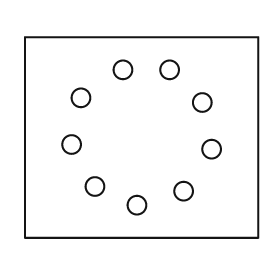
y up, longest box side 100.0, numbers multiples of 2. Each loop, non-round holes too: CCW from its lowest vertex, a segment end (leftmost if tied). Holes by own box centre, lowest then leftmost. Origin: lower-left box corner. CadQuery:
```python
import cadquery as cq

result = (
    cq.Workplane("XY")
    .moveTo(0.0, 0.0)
    .lineTo(100.0, 0.0)
    .lineTo(100.0, 86.0)
    .lineTo(0.0, 86.0)
    .close()
    .moveTo(48.0, 14.0)
    .circle(4.0)
    .moveTo(68.0, 20.0)
    .circle(4.0)
    .moveTo(30.0, 22.0)
    .circle(4.0)
    .moveTo(80.0, 38.0)
    .circle(4.0)
    .moveTo(20.0, 40.0)
    .circle(4.0)
    .moveTo(76.0, 58.0)
    .circle(4.0)
    .moveTo(24.0, 60.0)
    .circle(4.0)
    .moveTo(42.0, 72.0)
    .circle(4.0)
    .moveTo(62.0, 72.0)
    .circle(4.0)
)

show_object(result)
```